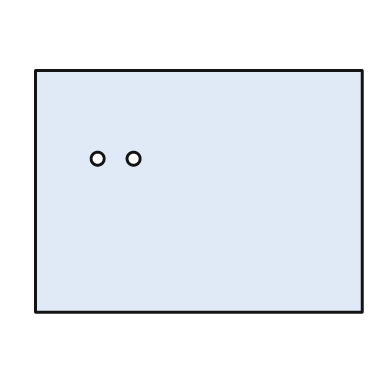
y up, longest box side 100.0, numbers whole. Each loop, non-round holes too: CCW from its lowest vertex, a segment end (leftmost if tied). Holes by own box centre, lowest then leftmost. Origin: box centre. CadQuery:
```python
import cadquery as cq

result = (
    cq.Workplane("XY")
    .moveTo(-50.0, -37.0)
    .lineTo(50.0, -37.0)
    .lineTo(50.0, 37.0)
    .lineTo(-50.0, 37.0)
    .close()
    .moveTo(-31.0, 10.0)
    .circle(2.0)
    .moveTo(-20.0, 10.0)
    .circle(2.0)
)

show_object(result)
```